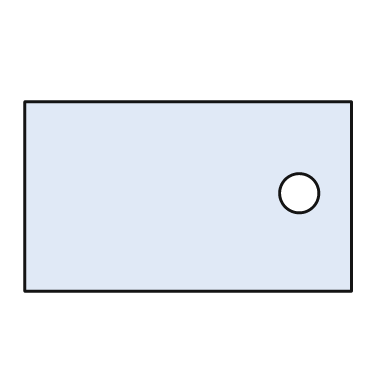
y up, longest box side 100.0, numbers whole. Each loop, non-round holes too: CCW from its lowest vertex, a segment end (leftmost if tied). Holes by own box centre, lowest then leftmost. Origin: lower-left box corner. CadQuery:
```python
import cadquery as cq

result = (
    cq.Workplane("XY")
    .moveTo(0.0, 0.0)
    .lineTo(100.0, 0.0)
    .lineTo(100.0, 58.0)
    .lineTo(0.0, 58.0)
    .close()
    .moveTo(84.0, 30.0)
    .circle(6.0)
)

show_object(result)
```